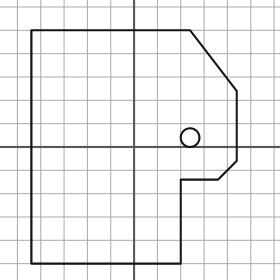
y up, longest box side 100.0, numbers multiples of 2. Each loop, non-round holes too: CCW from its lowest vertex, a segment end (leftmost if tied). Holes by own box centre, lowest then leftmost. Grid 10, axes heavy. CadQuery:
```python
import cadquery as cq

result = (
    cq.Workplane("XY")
    .moveTo(-44.0, -50.0)
    .lineTo(20.0, -50.0)
    .lineTo(20.0, -14.0)
    .lineTo(36.0, -14.0)
    .lineTo(44.0, -6.0)
    .lineTo(44.0, 24.0)
    .lineTo(24.0, 50.0)
    .lineTo(-44.0, 50.0)
    .close()
    .moveTo(24.0, 4.0)
    .circle(4.0)
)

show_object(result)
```